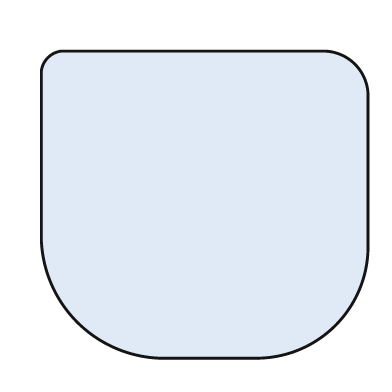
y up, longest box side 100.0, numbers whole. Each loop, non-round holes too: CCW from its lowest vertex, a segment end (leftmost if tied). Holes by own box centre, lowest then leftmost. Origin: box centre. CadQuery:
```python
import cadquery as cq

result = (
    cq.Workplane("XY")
    .moveTo(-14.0, -47.0)
    .lineTo(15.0, -47.0)
    .threePointArc((40.0, -37.0), (50.0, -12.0))
    .lineTo(50.0, 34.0)
    .threePointArc((46.0, 43.0), (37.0, 47.0))
    .lineTo(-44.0, 47.0)
    .threePointArc((-48.0, 45.0), (-50.0, 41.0))
    .lineTo(-50.0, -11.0)
    .threePointArc((-39.0, -36.0), (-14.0, -47.0))
    .close()
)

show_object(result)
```